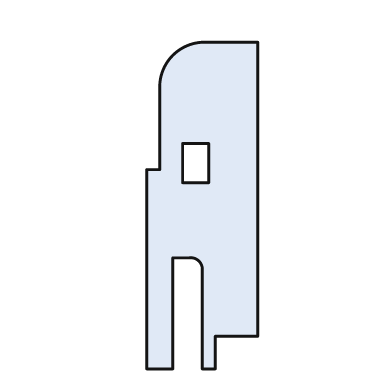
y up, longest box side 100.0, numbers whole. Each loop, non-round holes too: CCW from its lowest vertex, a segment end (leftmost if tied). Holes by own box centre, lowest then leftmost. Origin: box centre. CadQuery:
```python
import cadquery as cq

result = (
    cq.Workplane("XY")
    .moveTo(-17.0, -50.0)
    .lineTo(-9.0, -50.0)
    .lineTo(-9.0, -16.0)
    .lineTo(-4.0, -16.0)
    .threePointArc((-1.0, -17.0), (0.0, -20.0))
    .lineTo(0.0, -50.0)
    .lineTo(4.0, -50.0)
    .lineTo(4.0, -40.0)
    .lineTo(17.0, -40.0)
    .lineTo(17.0, 50.0)
    .lineTo(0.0, 50.0)
    .threePointArc((-9.0, 46.0), (-13.0, 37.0))
    .lineTo(-13.0, 11.0)
    .lineTo(-17.0, 11.0)
    .close()
    .moveTo(-6.0, 7.0)
    .lineTo(2.0, 7.0)
    .lineTo(2.0, 19.0)
    .lineTo(-6.0, 19.0)
    .close()
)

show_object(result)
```